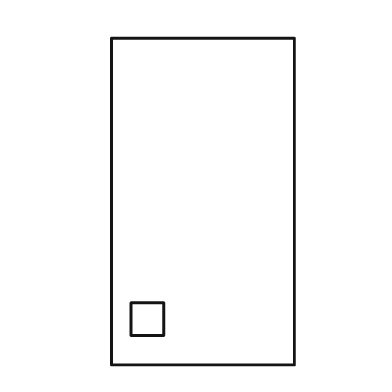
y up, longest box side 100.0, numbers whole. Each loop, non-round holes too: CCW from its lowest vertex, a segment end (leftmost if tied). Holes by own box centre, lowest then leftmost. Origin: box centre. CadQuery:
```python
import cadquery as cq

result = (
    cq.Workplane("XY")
    .moveTo(-28.0, -50.0)
    .lineTo(28.0, -50.0)
    .lineTo(28.0, 50.0)
    .lineTo(-28.0, 50.0)
    .close()
    .moveTo(-22.0, -41.0)
    .lineTo(-12.0, -41.0)
    .lineTo(-12.0, -31.0)
    .lineTo(-22.0, -31.0)
    .close()
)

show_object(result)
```